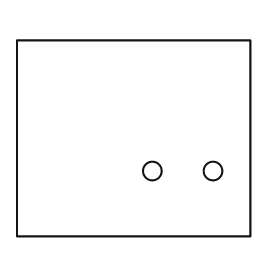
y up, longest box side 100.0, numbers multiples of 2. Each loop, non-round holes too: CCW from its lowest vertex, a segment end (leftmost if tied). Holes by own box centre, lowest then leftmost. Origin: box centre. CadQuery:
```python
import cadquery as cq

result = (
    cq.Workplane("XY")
    .moveTo(-50.0, -42.0)
    .lineTo(50.0, -42.0)
    .lineTo(50.0, 42.0)
    .lineTo(-50.0, 42.0)
    .close()
    .moveTo(8.0, -14.0)
    .circle(4.0)
    .moveTo(34.0, -14.0)
    .circle(4.0)
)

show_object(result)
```